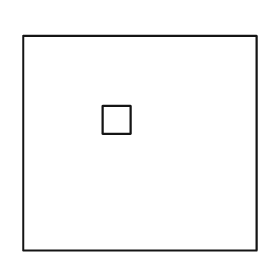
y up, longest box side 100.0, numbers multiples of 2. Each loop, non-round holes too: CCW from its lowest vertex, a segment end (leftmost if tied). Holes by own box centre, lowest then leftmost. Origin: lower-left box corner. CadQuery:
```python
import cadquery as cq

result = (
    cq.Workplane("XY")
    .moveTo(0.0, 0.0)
    .lineTo(100.0, 0.0)
    .lineTo(100.0, 92.0)
    .lineTo(0.0, 92.0)
    .close()
    .moveTo(34.0, 50.0)
    .lineTo(46.0, 50.0)
    .lineTo(46.0, 62.0)
    .lineTo(34.0, 62.0)
    .close()
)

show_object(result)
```